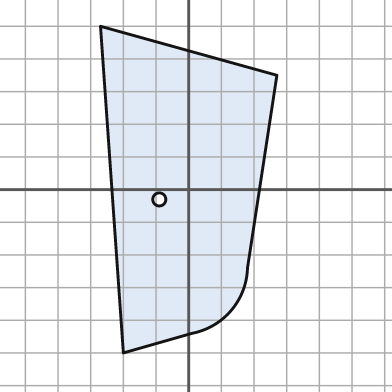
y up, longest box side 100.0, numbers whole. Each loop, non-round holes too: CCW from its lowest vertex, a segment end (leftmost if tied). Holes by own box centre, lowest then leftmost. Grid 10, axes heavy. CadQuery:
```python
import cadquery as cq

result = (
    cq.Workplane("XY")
    .moveTo(-20.0, -50.0)
    .lineTo(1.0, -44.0)
    .threePointArc((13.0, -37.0), (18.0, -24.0))
    .lineTo(27.0, 35.0)
    .lineTo(-27.0, 50.0)
    .close()
    .moveTo(-9.0, -3.0)
    .circle(2.0)
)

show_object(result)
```